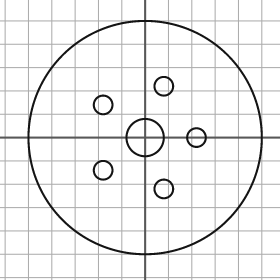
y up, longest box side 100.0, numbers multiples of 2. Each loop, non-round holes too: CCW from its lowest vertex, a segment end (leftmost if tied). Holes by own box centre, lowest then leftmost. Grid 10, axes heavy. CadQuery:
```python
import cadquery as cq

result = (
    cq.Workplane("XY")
    .moveTo(0.0, 0.0)
    .circle(50.0)
    .moveTo(8.0, -22.0)
    .circle(4.0)
    .moveTo(-18.0, -14.0)
    .circle(4.0)
    .moveTo(0.0, 0.0)
    .circle(8.0)
    .moveTo(22.0, 0.0)
    .circle(4.0)
    .moveTo(-18.0, 14.0)
    .circle(4.0)
    .moveTo(8.0, 22.0)
    .circle(4.0)
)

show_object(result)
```